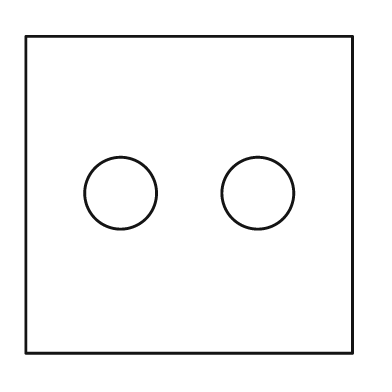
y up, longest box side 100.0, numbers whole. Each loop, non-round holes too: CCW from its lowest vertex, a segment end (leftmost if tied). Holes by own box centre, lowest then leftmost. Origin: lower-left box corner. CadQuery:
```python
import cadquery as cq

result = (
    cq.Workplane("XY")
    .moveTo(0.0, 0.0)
    .lineTo(100.0, 0.0)
    .lineTo(100.0, 97.0)
    .lineTo(0.0, 97.0)
    .close()
    .moveTo(29.0, 49.0)
    .circle(11.0)
    .moveTo(71.0, 49.0)
    .circle(11.0)
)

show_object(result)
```